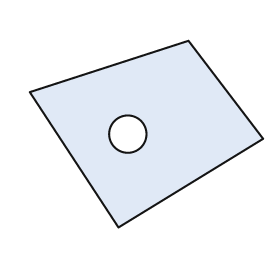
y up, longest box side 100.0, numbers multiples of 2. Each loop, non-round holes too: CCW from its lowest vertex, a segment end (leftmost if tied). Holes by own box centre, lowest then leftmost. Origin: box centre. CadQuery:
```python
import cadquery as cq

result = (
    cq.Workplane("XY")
    .moveTo(-12.0, -40.0)
    .lineTo(50.0, -2.0)
    .lineTo(18.0, 40.0)
    .lineTo(-50.0, 18.0)
    .close()
    .moveTo(-8.0, 0.0)
    .circle(8.0)
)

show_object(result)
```